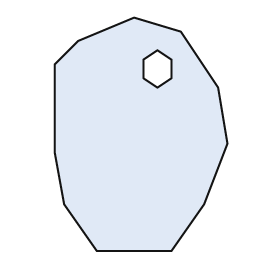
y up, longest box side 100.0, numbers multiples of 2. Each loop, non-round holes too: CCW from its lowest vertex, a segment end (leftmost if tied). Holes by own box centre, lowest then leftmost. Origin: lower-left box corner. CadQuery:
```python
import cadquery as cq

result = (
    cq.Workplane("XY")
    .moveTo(18.0, 0.0)
    .lineTo(50.0, 0.0)
    .lineTo(64.0, 20.0)
    .lineTo(74.0, 46.0)
    .lineTo(70.0, 70.0)
    .lineTo(54.0, 94.0)
    .lineTo(34.0, 100.0)
    .lineTo(10.0, 90.0)
    .lineTo(0.0, 80.0)
    .lineTo(0.0, 42.0)
    .lineTo(4.0, 20.0)
    .close()
    .moveTo(44.0, 70.0)
    .lineTo(50.0, 74.0)
    .lineTo(50.0, 82.0)
    .lineTo(44.0, 86.0)
    .lineTo(38.0, 82.0)
    .lineTo(38.0, 74.0)
    .close()
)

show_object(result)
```